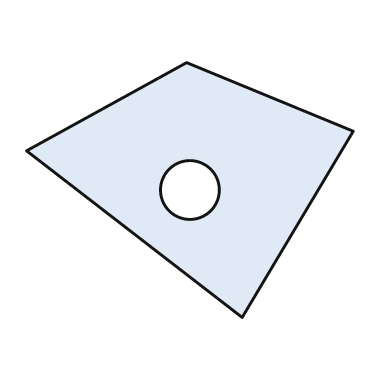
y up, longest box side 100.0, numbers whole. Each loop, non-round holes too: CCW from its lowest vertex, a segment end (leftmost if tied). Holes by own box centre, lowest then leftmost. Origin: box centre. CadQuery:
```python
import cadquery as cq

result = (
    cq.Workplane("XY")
    .moveTo(16.0, -39.0)
    .lineTo(50.0, 18.0)
    .lineTo(-1.0, 39.0)
    .lineTo(-50.0, 12.0)
    .close()
    .moveTo(0.0, 0.0)
    .circle(9.0)
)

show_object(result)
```